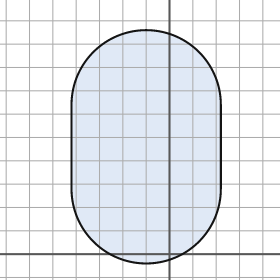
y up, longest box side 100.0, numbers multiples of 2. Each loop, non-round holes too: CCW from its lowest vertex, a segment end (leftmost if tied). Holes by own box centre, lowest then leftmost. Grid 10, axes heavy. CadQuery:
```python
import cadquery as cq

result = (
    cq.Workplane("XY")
    .moveTo(-42.0, 28.0)
    .threePointArc((-10.0, -4.0), (22.0, 28.0))
    .lineTo(22.0, 64.0)
    .threePointArc((-10.0, 96.0), (-42.0, 64.0))
    .close()
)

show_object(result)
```